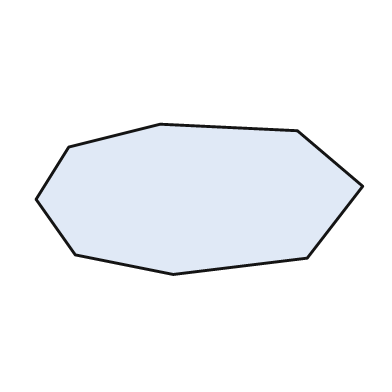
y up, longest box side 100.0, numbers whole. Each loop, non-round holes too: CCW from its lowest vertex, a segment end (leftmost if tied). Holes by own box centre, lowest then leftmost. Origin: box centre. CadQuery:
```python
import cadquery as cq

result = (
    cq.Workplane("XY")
    .moveTo(-8.0, -23.0)
    .lineTo(33.0, -18.0)
    .lineTo(50.0, 4.0)
    .lineTo(30.0, 21.0)
    .lineTo(-12.0, 23.0)
    .lineTo(-40.0, 16.0)
    .lineTo(-50.0, 0.0)
    .lineTo(-38.0, -17.0)
    .close()
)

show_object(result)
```